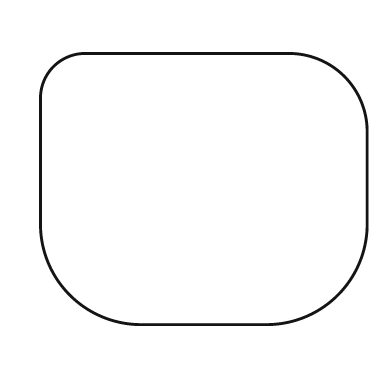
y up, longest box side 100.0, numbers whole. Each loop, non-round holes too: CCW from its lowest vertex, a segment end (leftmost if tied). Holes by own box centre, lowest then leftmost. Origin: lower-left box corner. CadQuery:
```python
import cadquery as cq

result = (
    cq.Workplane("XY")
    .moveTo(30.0, 0.0)
    .lineTo(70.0, 0.0)
    .threePointArc((91.0, 9.0), (100.0, 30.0))
    .lineTo(100.0, 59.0)
    .threePointArc((93.0, 76.0), (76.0, 83.0))
    .lineTo(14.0, 83.0)
    .threePointArc((4.0, 79.0), (0.0, 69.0))
    .lineTo(0.0, 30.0)
    .threePointArc((9.0, 9.0), (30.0, 0.0))
    .close()
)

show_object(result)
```